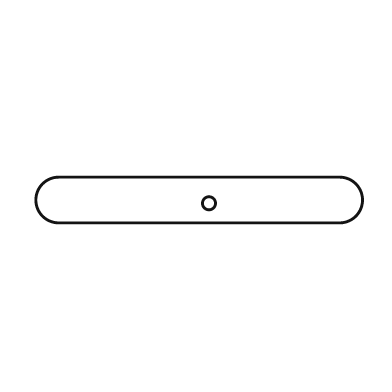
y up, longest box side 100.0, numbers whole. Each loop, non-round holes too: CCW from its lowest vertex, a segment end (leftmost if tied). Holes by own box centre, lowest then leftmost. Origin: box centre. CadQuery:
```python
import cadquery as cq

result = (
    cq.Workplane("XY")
    .moveTo(-43.0, -7.0)
    .lineTo(43.0, -7.0)
    .threePointArc((50.0, 0.0), (43.0, 7.0))
    .lineTo(-43.0, 7.0)
    .threePointArc((-50.0, 0.0), (-43.0, -7.0))
    .close()
    .moveTo(3.0, -1.0)
    .circle(2.0)
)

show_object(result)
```